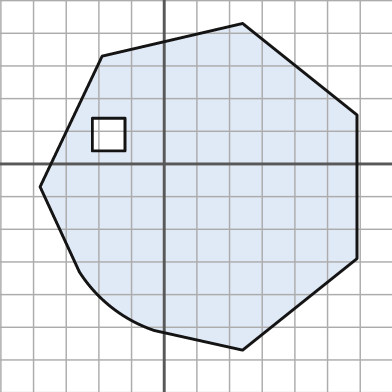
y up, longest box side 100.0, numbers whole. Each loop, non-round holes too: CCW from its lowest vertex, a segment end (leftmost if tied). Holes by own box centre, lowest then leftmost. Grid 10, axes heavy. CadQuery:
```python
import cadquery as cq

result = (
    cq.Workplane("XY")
    .moveTo(24.0, -57.0)
    .lineTo(59.0, -29.0)
    .lineTo(59.0, 15.0)
    .lineTo(24.0, 43.0)
    .lineTo(-19.0, 33.0)
    .lineTo(-38.0, -7.0)
    .lineTo(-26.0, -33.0)
    .threePointArc((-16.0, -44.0), (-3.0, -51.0))
    .close()
    .moveTo(-22.0, 4.0)
    .lineTo(-12.0, 4.0)
    .lineTo(-12.0, 14.0)
    .lineTo(-22.0, 14.0)
    .close()
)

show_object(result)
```